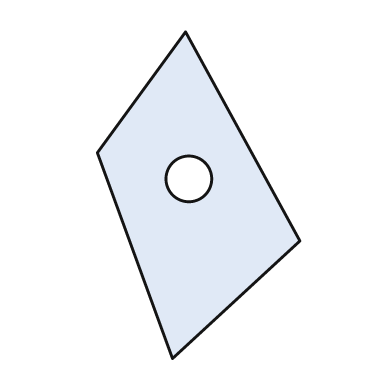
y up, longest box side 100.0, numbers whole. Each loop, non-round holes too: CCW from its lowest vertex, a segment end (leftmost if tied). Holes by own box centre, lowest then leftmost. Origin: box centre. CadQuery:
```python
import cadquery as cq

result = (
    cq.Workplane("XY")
    .moveTo(-8.0, -50.0)
    .lineTo(31.0, -14.0)
    .lineTo(-4.0, 50.0)
    .lineTo(-31.0, 13.0)
    .close()
    .moveTo(-3.0, 5.0)
    .circle(7.0)
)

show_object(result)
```